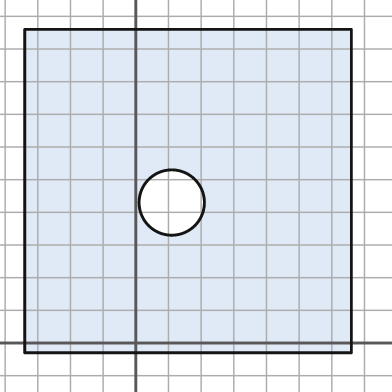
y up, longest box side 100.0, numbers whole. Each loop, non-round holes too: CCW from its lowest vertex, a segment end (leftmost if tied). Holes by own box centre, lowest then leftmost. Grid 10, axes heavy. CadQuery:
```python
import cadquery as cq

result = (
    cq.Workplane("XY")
    .moveTo(-34.0, -3.0)
    .lineTo(66.0, -3.0)
    .lineTo(66.0, 96.0)
    .lineTo(-34.0, 96.0)
    .close()
    .moveTo(11.0, 43.0)
    .circle(10.0)
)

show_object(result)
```